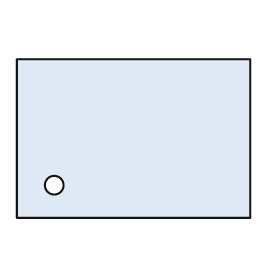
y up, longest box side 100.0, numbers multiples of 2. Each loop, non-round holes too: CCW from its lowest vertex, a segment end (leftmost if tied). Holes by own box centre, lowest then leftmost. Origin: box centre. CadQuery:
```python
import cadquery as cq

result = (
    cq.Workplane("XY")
    .moveTo(-50.0, -34.0)
    .lineTo(50.0, -34.0)
    .lineTo(50.0, 34.0)
    .lineTo(-50.0, 34.0)
    .close()
    .moveTo(-34.0, -20.0)
    .circle(4.0)
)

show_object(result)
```